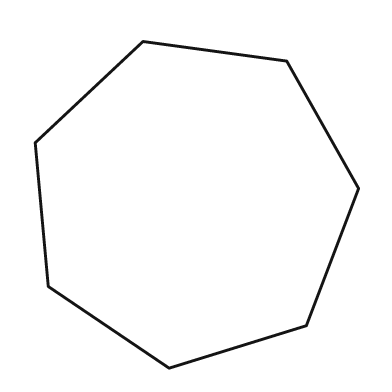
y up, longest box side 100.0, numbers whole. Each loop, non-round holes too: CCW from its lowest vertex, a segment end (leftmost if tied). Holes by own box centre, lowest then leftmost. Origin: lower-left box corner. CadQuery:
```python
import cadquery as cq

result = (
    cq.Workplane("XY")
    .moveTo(41.0, 0.0)
    .lineTo(83.0, 13.0)
    .lineTo(99.0, 55.0)
    .lineTo(77.0, 94.0)
    .lineTo(33.0, 100.0)
    .lineTo(0.0, 69.0)
    .lineTo(4.0, 25.0)
    .close()
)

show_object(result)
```